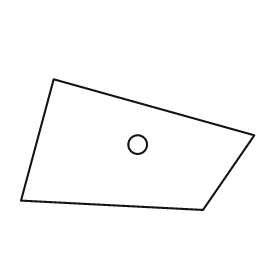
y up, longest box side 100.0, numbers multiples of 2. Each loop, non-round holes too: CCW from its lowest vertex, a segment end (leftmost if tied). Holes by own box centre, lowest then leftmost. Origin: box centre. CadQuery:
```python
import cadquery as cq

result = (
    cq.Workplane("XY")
    .moveTo(28.0, -28.0)
    .lineTo(50.0, 4.0)
    .lineTo(-36.0, 28.0)
    .lineTo(-50.0, -24.0)
    .close()
    .moveTo(0.0, 0.0)
    .circle(4.0)
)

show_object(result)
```